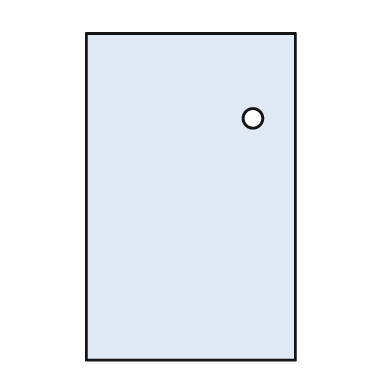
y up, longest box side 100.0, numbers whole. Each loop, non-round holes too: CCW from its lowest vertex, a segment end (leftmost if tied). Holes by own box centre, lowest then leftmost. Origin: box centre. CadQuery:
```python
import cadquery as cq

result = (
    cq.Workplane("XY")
    .moveTo(-32.0, -50.0)
    .lineTo(32.0, -50.0)
    .lineTo(32.0, 50.0)
    .lineTo(-32.0, 50.0)
    .close()
    .moveTo(19.0, 24.0)
    .circle(3.0)
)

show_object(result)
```